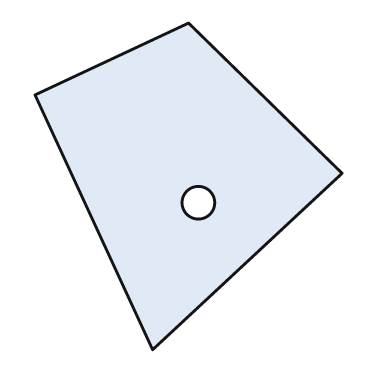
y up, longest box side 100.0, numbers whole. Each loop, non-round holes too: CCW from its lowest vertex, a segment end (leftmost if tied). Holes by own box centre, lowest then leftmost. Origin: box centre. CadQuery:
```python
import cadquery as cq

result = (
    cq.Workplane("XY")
    .moveTo(-11.0, -50.0)
    .lineTo(47.0, 4.0)
    .lineTo(0.0, 50.0)
    .lineTo(-47.0, 28.0)
    .close()
    .moveTo(3.0, -5.0)
    .circle(5.0)
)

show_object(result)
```